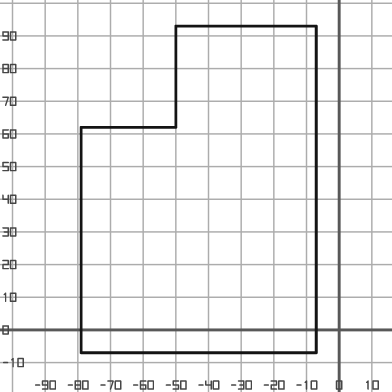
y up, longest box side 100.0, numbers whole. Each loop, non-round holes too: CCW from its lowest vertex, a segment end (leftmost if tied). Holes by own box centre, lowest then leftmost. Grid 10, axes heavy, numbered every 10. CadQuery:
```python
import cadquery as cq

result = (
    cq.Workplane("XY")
    .moveTo(-79.0, -7.0)
    .lineTo(-7.0, -7.0)
    .lineTo(-7.0, 93.0)
    .lineTo(-50.0, 93.0)
    .lineTo(-50.0, 62.0)
    .lineTo(-79.0, 62.0)
    .close()
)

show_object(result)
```